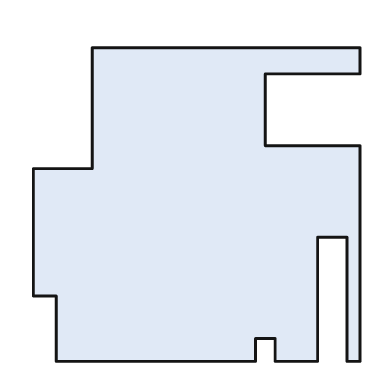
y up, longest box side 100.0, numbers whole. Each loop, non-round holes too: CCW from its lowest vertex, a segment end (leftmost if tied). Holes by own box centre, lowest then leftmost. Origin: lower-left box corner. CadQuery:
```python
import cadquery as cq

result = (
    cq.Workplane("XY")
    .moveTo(7.0, 0.0)
    .lineTo(68.0, 0.0)
    .lineTo(68.0, 7.0)
    .lineTo(74.0, 7.0)
    .lineTo(74.0, 0.0)
    .lineTo(87.0, 0.0)
    .lineTo(87.0, 38.0)
    .lineTo(96.0, 38.0)
    .lineTo(96.0, 0.0)
    .lineTo(100.0, 0.0)
    .lineTo(100.0, 66.0)
    .lineTo(71.0, 66.0)
    .lineTo(71.0, 88.0)
    .lineTo(100.0, 88.0)
    .lineTo(100.0, 96.0)
    .lineTo(18.0, 96.0)
    .lineTo(18.0, 59.0)
    .lineTo(0.0, 59.0)
    .lineTo(0.0, 20.0)
    .lineTo(7.0, 20.0)
    .close()
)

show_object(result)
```